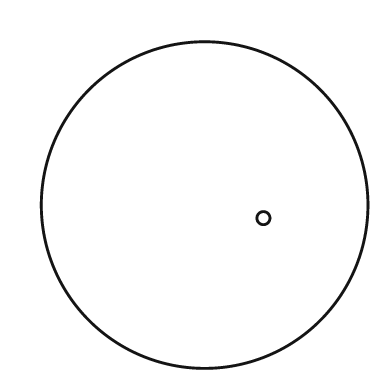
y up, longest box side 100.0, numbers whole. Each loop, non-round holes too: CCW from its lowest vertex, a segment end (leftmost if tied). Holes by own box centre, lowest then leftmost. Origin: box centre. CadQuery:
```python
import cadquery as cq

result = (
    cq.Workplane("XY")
    .moveTo(0.0, 0.0)
    .circle(50.0)
    .moveTo(18.0, -4.0)
    .circle(2.0)
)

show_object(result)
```